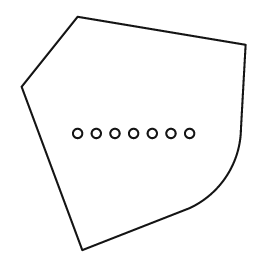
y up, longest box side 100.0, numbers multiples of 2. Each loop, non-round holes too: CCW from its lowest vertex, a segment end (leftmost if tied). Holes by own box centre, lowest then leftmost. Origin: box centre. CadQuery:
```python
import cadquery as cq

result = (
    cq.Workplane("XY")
    .moveTo(-22.0, -50.0)
    .lineTo(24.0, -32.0)
    .threePointArc((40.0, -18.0), (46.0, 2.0))
    .lineTo(48.0, 38.0)
    .lineTo(-24.0, 50.0)
    .lineTo(-48.0, 20.0)
    .close()
    .moveTo(-24.0, 0.0)
    .circle(2.0)
    .moveTo(-16.0, 0.0)
    .circle(2.0)
    .moveTo(-8.0, 0.0)
    .circle(2.0)
    .moveTo(0.0, 0.0)
    .circle(2.0)
    .moveTo(8.0, 0.0)
    .circle(2.0)
    .moveTo(16.0, 0.0)
    .circle(2.0)
    .moveTo(24.0, 0.0)
    .circle(2.0)
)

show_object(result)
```